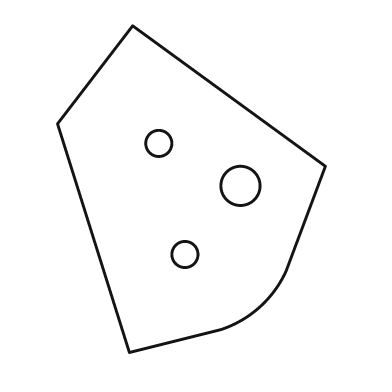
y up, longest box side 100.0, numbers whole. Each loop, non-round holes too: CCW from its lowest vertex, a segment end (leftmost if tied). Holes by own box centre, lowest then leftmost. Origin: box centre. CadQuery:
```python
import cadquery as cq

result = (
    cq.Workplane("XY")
    .moveTo(-19.0, -50.0)
    .lineTo(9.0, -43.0)
    .threePointArc((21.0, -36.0), (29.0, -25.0))
    .lineTo(41.0, 7.0)
    .lineTo(-18.0, 50.0)
    .lineTo(-41.0, 20.0)
    .close()
    .moveTo(-2.0, -20.0)
    .circle(4.0)
    .moveTo(15.0, 1.0)
    .circle(6.0)
    .moveTo(-10.0, 14.0)
    .circle(4.0)
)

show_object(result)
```